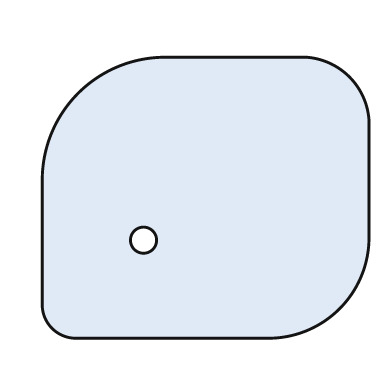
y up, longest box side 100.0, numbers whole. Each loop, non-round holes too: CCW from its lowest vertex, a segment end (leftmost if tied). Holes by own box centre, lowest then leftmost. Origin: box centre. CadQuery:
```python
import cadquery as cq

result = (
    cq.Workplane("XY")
    .moveTo(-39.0, -43.0)
    .lineTo(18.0, -43.0)
    .threePointArc((41.0, -34.0), (50.0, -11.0))
    .lineTo(50.0, 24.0)
    .threePointArc((44.0, 37.0), (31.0, 43.0))
    .lineTo(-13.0, 43.0)
    .threePointArc((-39.0, 32.0), (-50.0, 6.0))
    .lineTo(-50.0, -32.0)
    .threePointArc((-47.0, -40.0), (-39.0, -43.0))
    .close()
    .moveTo(-19.0, -13.0)
    .circle(4.0)
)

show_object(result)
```